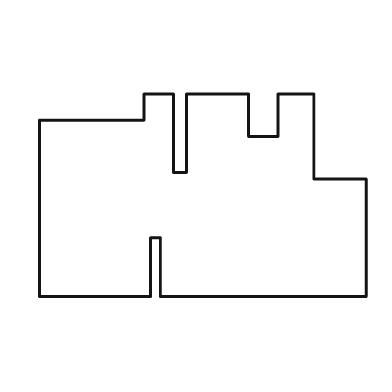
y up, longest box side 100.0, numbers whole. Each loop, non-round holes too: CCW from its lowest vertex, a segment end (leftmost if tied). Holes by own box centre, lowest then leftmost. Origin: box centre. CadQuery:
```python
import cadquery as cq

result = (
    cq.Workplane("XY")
    .moveTo(-50.0, -31.0)
    .lineTo(-16.0, -31.0)
    .lineTo(-16.0, -13.0)
    .lineTo(-13.0, -13.0)
    .lineTo(-13.0, -31.0)
    .lineTo(50.0, -31.0)
    .lineTo(50.0, 5.0)
    .lineTo(34.0, 5.0)
    .lineTo(34.0, 31.0)
    .lineTo(23.0, 31.0)
    .lineTo(23.0, 18.0)
    .lineTo(14.0, 18.0)
    .lineTo(14.0, 31.0)
    .lineTo(-5.0, 31.0)
    .lineTo(-5.0, 7.0)
    .lineTo(-9.0, 7.0)
    .lineTo(-9.0, 31.0)
    .lineTo(-18.0, 31.0)
    .lineTo(-18.0, 23.0)
    .lineTo(-50.0, 23.0)
    .close()
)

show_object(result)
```